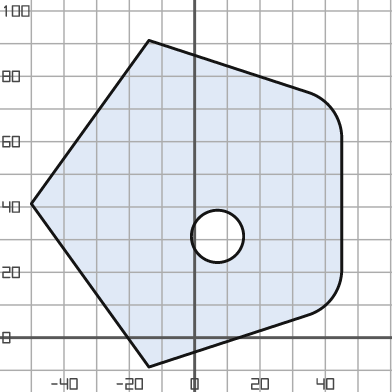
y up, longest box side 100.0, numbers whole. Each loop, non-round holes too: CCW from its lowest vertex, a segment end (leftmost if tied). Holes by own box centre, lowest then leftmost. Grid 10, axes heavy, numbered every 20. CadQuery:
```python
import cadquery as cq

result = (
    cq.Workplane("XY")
    .moveTo(-14.0, -9.0)
    .lineTo(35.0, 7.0)
    .threePointArc((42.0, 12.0), (45.0, 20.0))
    .lineTo(45.0, 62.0)
    .threePointArc((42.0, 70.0), (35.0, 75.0))
    .lineTo(-14.0, 91.0)
    .lineTo(-50.0, 41.0)
    .close()
    .moveTo(7.0, 31.0)
    .circle(8.0)
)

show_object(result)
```